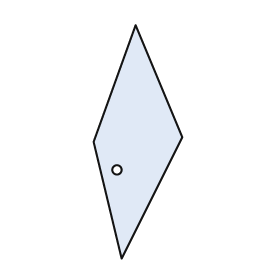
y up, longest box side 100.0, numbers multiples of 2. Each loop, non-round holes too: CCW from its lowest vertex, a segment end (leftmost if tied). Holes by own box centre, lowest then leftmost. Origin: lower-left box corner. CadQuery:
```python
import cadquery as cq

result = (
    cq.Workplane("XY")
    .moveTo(12.0, 0.0)
    .lineTo(38.0, 52.0)
    .lineTo(18.0, 100.0)
    .lineTo(0.0, 50.0)
    .close()
    .moveTo(10.0, 38.0)
    .circle(2.0)
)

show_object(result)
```